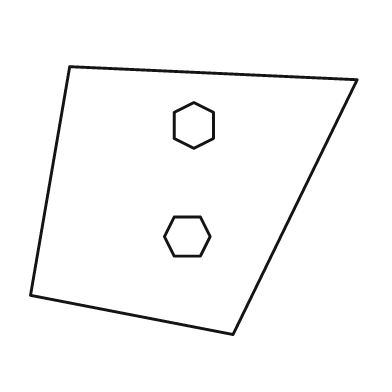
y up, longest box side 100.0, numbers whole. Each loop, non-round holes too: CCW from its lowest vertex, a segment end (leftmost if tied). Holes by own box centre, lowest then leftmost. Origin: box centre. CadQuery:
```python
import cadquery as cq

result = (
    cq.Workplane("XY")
    .moveTo(12.0, -41.0)
    .lineTo(50.0, 37.0)
    .lineTo(-38.0, 41.0)
    .lineTo(-50.0, -29.0)
    .close()
    .moveTo(-6.0, -17.0)
    .lineTo(2.0, -17.0)
    .lineTo(5.0, -11.0)
    .lineTo(2.0, -5.0)
    .lineTo(-6.0, -5.0)
    .lineTo(-9.0, -11.0)
    .close()
    .moveTo(0.0, 16.0)
    .lineTo(6.0, 19.0)
    .lineTo(6.0, 27.0)
    .lineTo(0.0, 30.0)
    .lineTo(-6.0, 27.0)
    .lineTo(-6.0, 19.0)
    .close()
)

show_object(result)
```